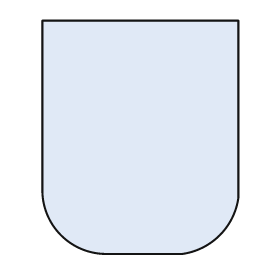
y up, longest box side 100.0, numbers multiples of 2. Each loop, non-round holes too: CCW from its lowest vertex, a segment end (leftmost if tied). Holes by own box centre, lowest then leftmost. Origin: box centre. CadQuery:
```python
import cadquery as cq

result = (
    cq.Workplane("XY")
    .moveTo(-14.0, -50.0)
    .lineTo(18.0, -50.0)
    .threePointArc((34.0, -42.0), (42.0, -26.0))
    .lineTo(42.0, 50.0)
    .lineTo(-42.0, 50.0)
    .lineTo(-42.0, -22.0)
    .threePointArc((-34.0, -42.0), (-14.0, -50.0))
    .close()
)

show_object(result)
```